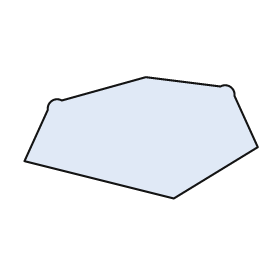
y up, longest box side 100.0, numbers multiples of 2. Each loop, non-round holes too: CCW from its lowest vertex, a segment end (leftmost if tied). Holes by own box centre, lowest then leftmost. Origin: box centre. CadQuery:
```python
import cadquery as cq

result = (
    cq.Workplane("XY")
    .moveTo(14.0, -26.0)
    .lineTo(50.0, -4.0)
    .lineTo(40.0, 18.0)
    .threePointArc((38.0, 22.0), (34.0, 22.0))
    .lineTo(2.0, 26.0)
    .lineTo(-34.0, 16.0)
    .threePointArc((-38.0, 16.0), (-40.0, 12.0))
    .lineTo(-50.0, -10.0)
    .close()
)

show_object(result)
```